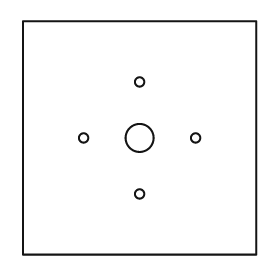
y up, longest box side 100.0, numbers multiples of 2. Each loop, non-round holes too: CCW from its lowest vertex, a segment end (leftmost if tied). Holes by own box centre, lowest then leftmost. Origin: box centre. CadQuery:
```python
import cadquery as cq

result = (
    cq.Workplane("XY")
    .moveTo(-50.0, -50.0)
    .lineTo(50.0, -50.0)
    .lineTo(50.0, 50.0)
    .lineTo(-50.0, 50.0)
    .close()
    .moveTo(0.0, -24.0)
    .circle(2.0)
    .moveTo(-24.0, 0.0)
    .circle(2.0)
    .moveTo(0.0, 0.0)
    .circle(6.0)
    .moveTo(24.0, 0.0)
    .circle(2.0)
    .moveTo(0.0, 24.0)
    .circle(2.0)
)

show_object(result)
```